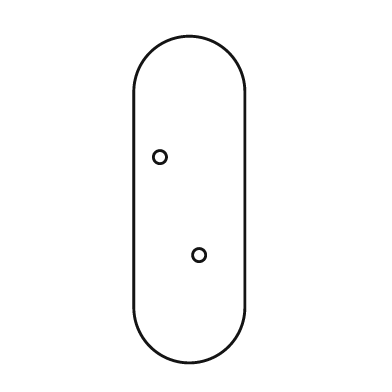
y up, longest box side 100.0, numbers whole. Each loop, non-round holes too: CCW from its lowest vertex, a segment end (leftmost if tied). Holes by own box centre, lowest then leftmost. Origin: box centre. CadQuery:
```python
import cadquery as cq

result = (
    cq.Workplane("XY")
    .moveTo(-17.0, -33.0)
    .threePointArc((0.0, -50.0), (17.0, -33.0))
    .lineTo(17.0, 33.0)
    .threePointArc((0.0, 50.0), (-17.0, 33.0))
    .close()
    .moveTo(3.0, -17.0)
    .circle(2.0)
    .moveTo(-9.0, 13.0)
    .circle(2.0)
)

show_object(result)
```